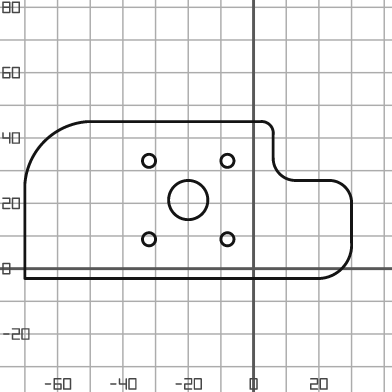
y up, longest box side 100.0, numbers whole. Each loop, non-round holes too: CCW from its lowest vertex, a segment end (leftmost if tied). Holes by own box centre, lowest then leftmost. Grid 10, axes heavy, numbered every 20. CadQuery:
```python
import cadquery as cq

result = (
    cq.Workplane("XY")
    .moveTo(-70.0, -3.0)
    .lineTo(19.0, -3.0)
    .threePointArc((27.0, 0.0), (30.0, 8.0))
    .lineTo(30.0, 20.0)
    .threePointArc((28.0, 25.0), (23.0, 27.0))
    .lineTo(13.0, 27.0)
    .threePointArc((8.0, 29.0), (6.0, 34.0))
    .lineTo(6.0, 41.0)
    .threePointArc((5.0, 44.0), (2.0, 45.0))
    .lineTo(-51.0, 45.0)
    .threePointArc((-64.0, 39.0), (-70.0, 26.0))
    .close()
    .moveTo(-32.0, 9.0)
    .circle(2.0)
    .moveTo(-8.0, 9.0)
    .circle(2.0)
    .moveTo(-20.0, 21.0)
    .circle(6.0)
    .moveTo(-32.0, 33.0)
    .circle(2.0)
    .moveTo(-8.0, 33.0)
    .circle(2.0)
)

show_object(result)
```